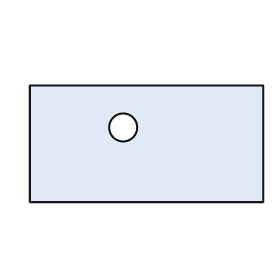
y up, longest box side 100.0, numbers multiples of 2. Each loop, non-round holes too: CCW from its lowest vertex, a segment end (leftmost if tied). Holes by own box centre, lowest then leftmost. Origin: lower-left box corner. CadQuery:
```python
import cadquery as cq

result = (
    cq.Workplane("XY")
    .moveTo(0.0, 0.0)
    .lineTo(100.0, 0.0)
    .lineTo(100.0, 50.0)
    .lineTo(0.0, 50.0)
    .close()
    .moveTo(40.0, 32.0)
    .circle(6.0)
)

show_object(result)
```